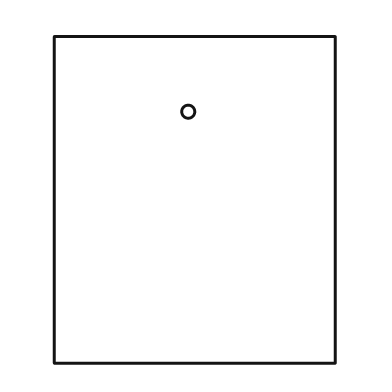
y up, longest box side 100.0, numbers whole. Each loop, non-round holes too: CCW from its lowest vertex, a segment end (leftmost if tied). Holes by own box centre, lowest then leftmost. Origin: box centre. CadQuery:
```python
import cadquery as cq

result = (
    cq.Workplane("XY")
    .moveTo(-43.0, -50.0)
    .lineTo(43.0, -50.0)
    .lineTo(43.0, 50.0)
    .lineTo(-43.0, 50.0)
    .close()
    .moveTo(-2.0, 27.0)
    .circle(2.0)
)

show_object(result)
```